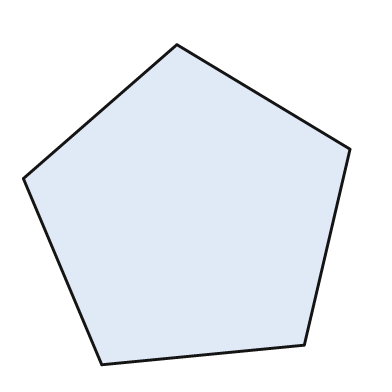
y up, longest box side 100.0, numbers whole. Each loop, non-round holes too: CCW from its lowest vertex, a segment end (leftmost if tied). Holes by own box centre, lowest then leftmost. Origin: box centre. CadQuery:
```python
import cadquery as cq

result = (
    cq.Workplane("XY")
    .moveTo(-26.0, -49.0)
    .lineTo(36.0, -43.0)
    .lineTo(50.0, 17.0)
    .lineTo(-3.0, 49.0)
    .lineTo(-50.0, 8.0)
    .close()
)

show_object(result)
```